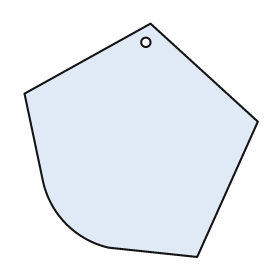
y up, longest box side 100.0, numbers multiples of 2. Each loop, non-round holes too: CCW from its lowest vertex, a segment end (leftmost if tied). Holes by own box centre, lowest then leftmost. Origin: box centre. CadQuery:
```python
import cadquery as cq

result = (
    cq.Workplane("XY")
    .moveTo(24.0, -50.0)
    .lineTo(50.0, 8.0)
    .lineTo(4.0, 50.0)
    .lineTo(-50.0, 20.0)
    .lineTo(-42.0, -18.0)
    .threePointArc((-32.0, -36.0), (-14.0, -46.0))
    .close()
    .moveTo(2.0, 42.0)
    .circle(2.0)
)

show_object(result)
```